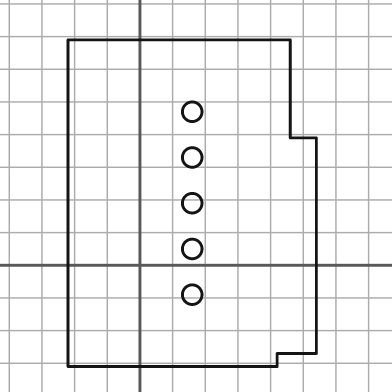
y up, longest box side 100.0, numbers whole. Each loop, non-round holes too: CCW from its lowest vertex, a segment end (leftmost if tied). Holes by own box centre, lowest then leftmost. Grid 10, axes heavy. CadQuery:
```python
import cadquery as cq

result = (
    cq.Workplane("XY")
    .moveTo(-22.0, -31.0)
    .lineTo(42.0, -31.0)
    .lineTo(42.0, -27.0)
    .lineTo(54.0, -27.0)
    .lineTo(54.0, 39.0)
    .lineTo(46.0, 39.0)
    .lineTo(46.0, 69.0)
    .lineTo(-22.0, 69.0)
    .close()
    .moveTo(16.0, -9.0)
    .circle(3.0)
    .moveTo(16.0, 5.0)
    .circle(3.0)
    .moveTo(16.0, 19.0)
    .circle(3.0)
    .moveTo(16.0, 33.0)
    .circle(3.0)
    .moveTo(16.0, 47.0)
    .circle(3.0)
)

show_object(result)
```